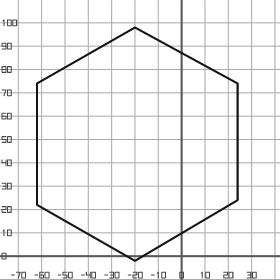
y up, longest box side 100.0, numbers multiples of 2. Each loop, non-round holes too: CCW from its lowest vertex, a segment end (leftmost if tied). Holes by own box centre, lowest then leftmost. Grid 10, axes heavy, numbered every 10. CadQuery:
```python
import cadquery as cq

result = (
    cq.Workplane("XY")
    .moveTo(-20.0, -2.0)
    .lineTo(24.0, 24.0)
    .lineTo(24.0, 74.0)
    .lineTo(-20.0, 98.0)
    .lineTo(-62.0, 74.0)
    .lineTo(-62.0, 22.0)
    .close()
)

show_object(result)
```